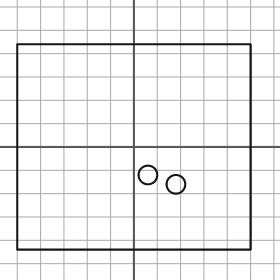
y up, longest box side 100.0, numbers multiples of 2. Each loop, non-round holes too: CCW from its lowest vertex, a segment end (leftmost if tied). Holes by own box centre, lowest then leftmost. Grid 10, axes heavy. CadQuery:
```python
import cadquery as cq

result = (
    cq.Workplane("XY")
    .moveTo(-50.0, -44.0)
    .lineTo(50.0, -44.0)
    .lineTo(50.0, 44.0)
    .lineTo(-50.0, 44.0)
    .close()
    .moveTo(18.0, -16.0)
    .circle(4.0)
    .moveTo(6.0, -12.0)
    .circle(4.0)
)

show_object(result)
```